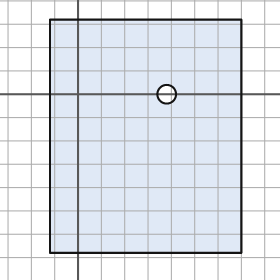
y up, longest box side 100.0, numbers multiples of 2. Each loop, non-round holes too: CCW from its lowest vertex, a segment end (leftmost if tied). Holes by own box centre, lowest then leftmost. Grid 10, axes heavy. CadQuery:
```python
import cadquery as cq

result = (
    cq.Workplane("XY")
    .moveTo(-12.0, -68.0)
    .lineTo(70.0, -68.0)
    .lineTo(70.0, 32.0)
    .lineTo(-12.0, 32.0)
    .close()
    .moveTo(38.0, 0.0)
    .circle(4.0)
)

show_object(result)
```